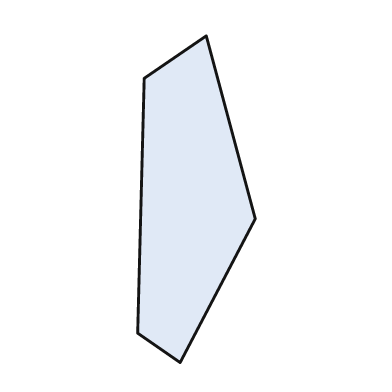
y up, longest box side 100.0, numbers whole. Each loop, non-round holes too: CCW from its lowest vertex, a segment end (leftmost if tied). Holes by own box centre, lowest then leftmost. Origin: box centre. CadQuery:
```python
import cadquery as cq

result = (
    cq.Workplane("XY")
    .moveTo(-5.0, -50.0)
    .lineTo(18.0, -6.0)
    .lineTo(3.0, 50.0)
    .lineTo(-16.0, 37.0)
    .lineTo(-18.0, -41.0)
    .close()
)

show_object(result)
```